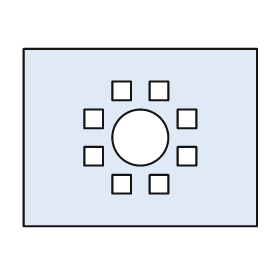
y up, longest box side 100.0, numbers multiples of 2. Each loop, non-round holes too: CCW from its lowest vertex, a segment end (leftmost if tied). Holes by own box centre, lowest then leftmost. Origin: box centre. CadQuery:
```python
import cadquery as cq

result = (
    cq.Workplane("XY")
    .moveTo(-50.0, -38.0)
    .lineTo(50.0, -38.0)
    .lineTo(50.0, 38.0)
    .lineTo(-50.0, 38.0)
    .close()
    .moveTo(-12.0, -24.0)
    .lineTo(-4.0, -24.0)
    .lineTo(-4.0, -16.0)
    .lineTo(-12.0, -16.0)
    .close()
    .moveTo(4.0, -24.0)
    .lineTo(12.0, -24.0)
    .lineTo(12.0, -16.0)
    .lineTo(4.0, -16.0)
    .close()
    .moveTo(-24.0, -12.0)
    .lineTo(-16.0, -12.0)
    .lineTo(-16.0, -4.0)
    .lineTo(-24.0, -4.0)
    .close()
    .moveTo(16.0, -12.0)
    .lineTo(24.0, -12.0)
    .lineTo(24.0, -4.0)
    .lineTo(16.0, -4.0)
    .close()
    .moveTo(0.0, 0.0)
    .circle(12.0)
    .moveTo(-24.0, 4.0)
    .lineTo(-16.0, 4.0)
    .lineTo(-16.0, 12.0)
    .lineTo(-24.0, 12.0)
    .close()
    .moveTo(16.0, 4.0)
    .lineTo(24.0, 4.0)
    .lineTo(24.0, 12.0)
    .lineTo(16.0, 12.0)
    .close()
    .moveTo(-12.0, 16.0)
    .lineTo(-4.0, 16.0)
    .lineTo(-4.0, 24.0)
    .lineTo(-12.0, 24.0)
    .close()
    .moveTo(4.0, 16.0)
    .lineTo(12.0, 16.0)
    .lineTo(12.0, 24.0)
    .lineTo(4.0, 24.0)
    .close()
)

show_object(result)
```